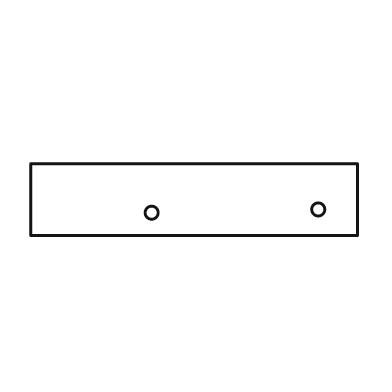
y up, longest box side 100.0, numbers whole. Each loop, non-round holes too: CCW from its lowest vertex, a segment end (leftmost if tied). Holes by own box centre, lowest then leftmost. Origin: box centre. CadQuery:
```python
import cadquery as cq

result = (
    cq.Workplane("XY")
    .moveTo(-50.0, -11.0)
    .lineTo(50.0, -11.0)
    .lineTo(50.0, 11.0)
    .lineTo(-50.0, 11.0)
    .close()
    .moveTo(-13.0, -4.0)
    .circle(2.0)
    .moveTo(38.0, -3.0)
    .circle(2.0)
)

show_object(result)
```